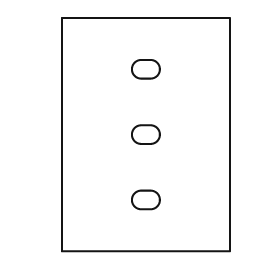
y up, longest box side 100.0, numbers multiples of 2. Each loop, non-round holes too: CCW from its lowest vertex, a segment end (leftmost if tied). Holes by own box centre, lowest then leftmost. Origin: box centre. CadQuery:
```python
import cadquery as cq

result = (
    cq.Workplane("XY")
    .moveTo(-36.0, -50.0)
    .lineTo(36.0, -50.0)
    .lineTo(36.0, 50.0)
    .lineTo(-36.0, 50.0)
    .close()
    .moveTo(-2.0, -32.0)
    .lineTo(2.0, -32.0)
    .threePointArc((6.0, -28.0), (2.0, -24.0))
    .lineTo(-2.0, -24.0)
    .threePointArc((-6.0, -28.0), (-2.0, -32.0))
    .close()
    .moveTo(-2.0, -4.0)
    .lineTo(2.0, -4.0)
    .threePointArc((6.0, 0.0), (2.0, 4.0))
    .lineTo(-2.0, 4.0)
    .threePointArc((-6.0, 0.0), (-2.0, -4.0))
    .close()
    .moveTo(-2.0, 24.0)
    .lineTo(2.0, 24.0)
    .threePointArc((6.0, 28.0), (2.0, 32.0))
    .lineTo(-2.0, 32.0)
    .threePointArc((-6.0, 28.0), (-2.0, 24.0))
    .close()
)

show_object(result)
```